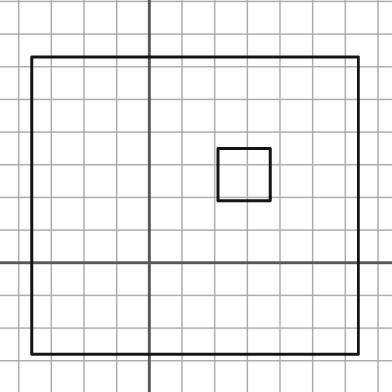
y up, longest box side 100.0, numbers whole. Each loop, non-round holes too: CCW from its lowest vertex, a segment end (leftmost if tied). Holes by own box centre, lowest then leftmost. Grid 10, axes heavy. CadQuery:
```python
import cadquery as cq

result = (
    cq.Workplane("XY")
    .moveTo(-36.0, -28.0)
    .lineTo(64.0, -28.0)
    .lineTo(64.0, 63.0)
    .lineTo(-36.0, 63.0)
    .close()
    .moveTo(21.0, 19.0)
    .lineTo(37.0, 19.0)
    .lineTo(37.0, 35.0)
    .lineTo(21.0, 35.0)
    .close()
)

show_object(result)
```